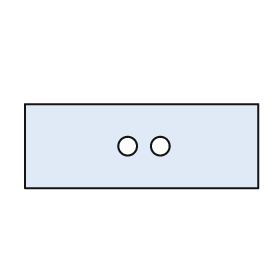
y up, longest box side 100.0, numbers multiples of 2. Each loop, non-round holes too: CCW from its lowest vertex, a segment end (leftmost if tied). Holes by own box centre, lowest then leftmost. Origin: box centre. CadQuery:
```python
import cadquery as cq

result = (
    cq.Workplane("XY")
    .moveTo(-50.0, -18.0)
    .lineTo(50.0, -18.0)
    .lineTo(50.0, 18.0)
    .lineTo(-50.0, 18.0)
    .close()
    .moveTo(-6.0, 0.0)
    .circle(4.0)
    .moveTo(8.0, 0.0)
    .circle(4.0)
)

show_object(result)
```